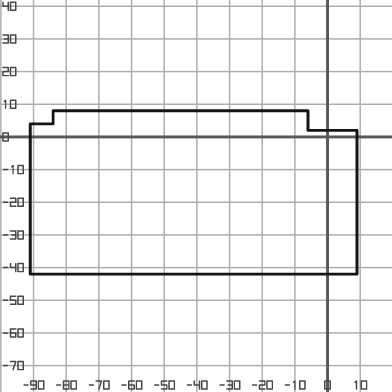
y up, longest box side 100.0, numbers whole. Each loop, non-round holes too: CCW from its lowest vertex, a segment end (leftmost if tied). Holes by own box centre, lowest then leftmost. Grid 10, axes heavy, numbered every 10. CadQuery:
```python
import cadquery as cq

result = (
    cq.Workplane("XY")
    .moveTo(-91.0, -42.0)
    .lineTo(9.0, -42.0)
    .lineTo(9.0, 2.0)
    .lineTo(-6.0, 2.0)
    .lineTo(-6.0, 8.0)
    .lineTo(-84.0, 8.0)
    .lineTo(-84.0, 4.0)
    .lineTo(-91.0, 4.0)
    .close()
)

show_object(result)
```